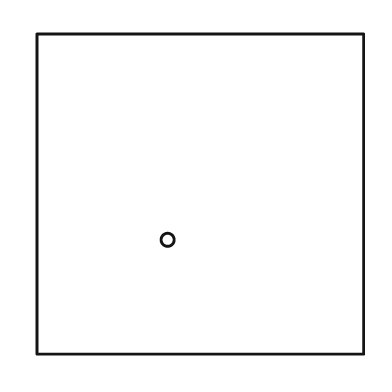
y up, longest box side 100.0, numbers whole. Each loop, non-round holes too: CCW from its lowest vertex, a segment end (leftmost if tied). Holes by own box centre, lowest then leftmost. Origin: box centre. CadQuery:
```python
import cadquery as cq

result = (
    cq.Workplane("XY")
    .moveTo(-50.0, -49.0)
    .lineTo(50.0, -49.0)
    .lineTo(50.0, 49.0)
    .lineTo(-50.0, 49.0)
    .close()
    .moveTo(-10.0, -14.0)
    .circle(2.0)
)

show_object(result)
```